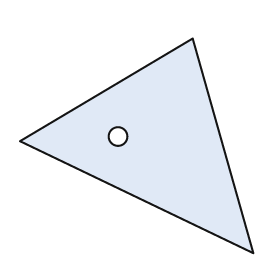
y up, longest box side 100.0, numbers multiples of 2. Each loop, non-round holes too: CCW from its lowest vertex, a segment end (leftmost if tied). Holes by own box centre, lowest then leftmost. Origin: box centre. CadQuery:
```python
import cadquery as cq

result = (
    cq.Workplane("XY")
    .moveTo(50.0, -46.0)
    .lineTo(24.0, 46.0)
    .lineTo(-50.0, 2.0)
    .close()
    .moveTo(-8.0, 4.0)
    .circle(4.0)
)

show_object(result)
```